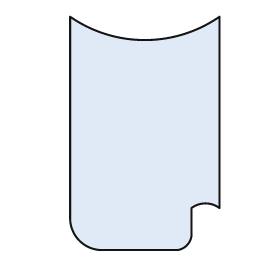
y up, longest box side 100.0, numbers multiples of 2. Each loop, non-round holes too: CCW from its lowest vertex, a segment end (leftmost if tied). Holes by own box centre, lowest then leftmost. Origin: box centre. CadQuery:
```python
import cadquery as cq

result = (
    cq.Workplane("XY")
    .moveTo(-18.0, -50.0)
    .lineTo(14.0, -50.0)
    .threePointArc((18.0, -48.0), (20.0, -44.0))
    .lineTo(20.0, -32.0)
    .threePointArc((26.0, -30.0), (32.0, -32.0))
    .lineTo(32.0, 50.0)
    .threePointArc((0.0, 40.0), (-32.0, 50.0))
    .lineTo(-32.0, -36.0)
    .threePointArc((-28.0, -46.0), (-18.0, -50.0))
    .close()
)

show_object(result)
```